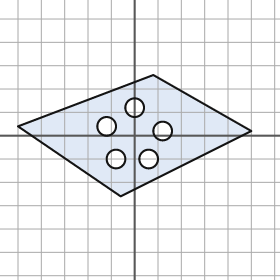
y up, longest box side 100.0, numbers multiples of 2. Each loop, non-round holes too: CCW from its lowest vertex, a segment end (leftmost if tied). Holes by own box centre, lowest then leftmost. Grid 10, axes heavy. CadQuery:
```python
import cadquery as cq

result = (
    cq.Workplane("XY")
    .moveTo(-6.0, -26.0)
    .lineTo(50.0, 2.0)
    .lineTo(8.0, 26.0)
    .lineTo(-50.0, 4.0)
    .close()
    .moveTo(-8.0, -10.0)
    .circle(4.0)
    .moveTo(6.0, -10.0)
    .circle(4.0)
    .moveTo(12.0, 2.0)
    .circle(4.0)
    .moveTo(-12.0, 4.0)
    .circle(4.0)
    .moveTo(0.0, 12.0)
    .circle(4.0)
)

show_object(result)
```